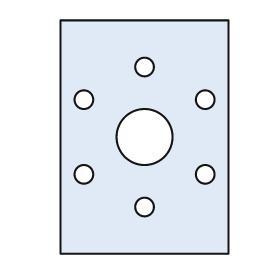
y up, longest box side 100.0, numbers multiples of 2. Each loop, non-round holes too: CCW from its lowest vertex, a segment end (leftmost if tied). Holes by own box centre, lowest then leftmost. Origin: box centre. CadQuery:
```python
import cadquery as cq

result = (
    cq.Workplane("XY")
    .moveTo(-36.0, -50.0)
    .lineTo(36.0, -50.0)
    .lineTo(36.0, 50.0)
    .lineTo(-36.0, 50.0)
    .close()
    .moveTo(0.0, -30.0)
    .circle(4.0)
    .moveTo(-26.0, -16.0)
    .circle(4.0)
    .moveTo(26.0, -16.0)
    .circle(4.0)
    .moveTo(0.0, 0.0)
    .circle(12.0)
    .moveTo(-26.0, 16.0)
    .circle(4.0)
    .moveTo(26.0, 16.0)
    .circle(4.0)
    .moveTo(0.0, 30.0)
    .circle(4.0)
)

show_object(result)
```